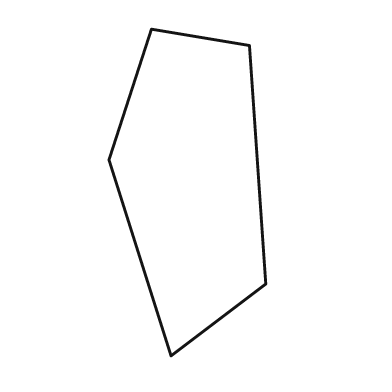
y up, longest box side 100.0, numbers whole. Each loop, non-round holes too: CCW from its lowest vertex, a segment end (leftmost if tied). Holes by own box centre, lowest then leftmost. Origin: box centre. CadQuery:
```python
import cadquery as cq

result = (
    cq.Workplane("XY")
    .moveTo(-5.0, -50.0)
    .lineTo(24.0, -28.0)
    .lineTo(19.0, 45.0)
    .lineTo(-11.0, 50.0)
    .lineTo(-24.0, 10.0)
    .close()
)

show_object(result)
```